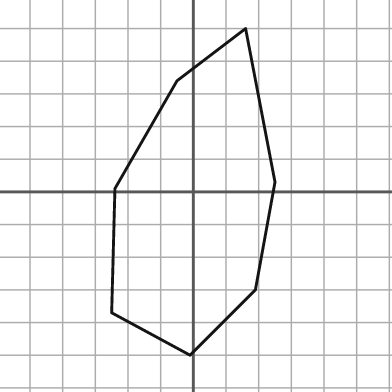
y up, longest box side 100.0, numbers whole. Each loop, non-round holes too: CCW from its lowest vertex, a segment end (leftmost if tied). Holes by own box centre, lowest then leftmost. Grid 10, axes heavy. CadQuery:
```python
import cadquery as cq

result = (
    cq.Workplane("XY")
    .moveTo(-1.0, -50.0)
    .lineTo(19.0, -30.0)
    .lineTo(25.0, 3.0)
    .lineTo(16.0, 50.0)
    .lineTo(-5.0, 34.0)
    .lineTo(-24.0, 1.0)
    .lineTo(-25.0, -37.0)
    .close()
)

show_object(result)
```